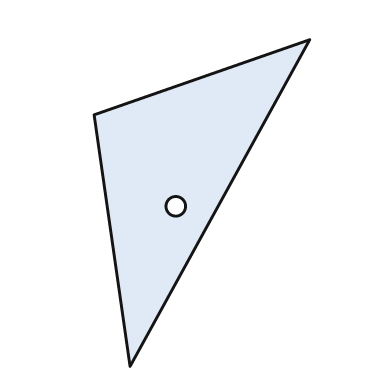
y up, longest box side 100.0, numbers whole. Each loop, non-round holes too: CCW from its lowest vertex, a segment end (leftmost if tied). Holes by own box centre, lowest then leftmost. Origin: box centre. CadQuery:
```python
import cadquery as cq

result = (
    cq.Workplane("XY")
    .moveTo(-22.0, -50.0)
    .lineTo(33.0, 50.0)
    .lineTo(-33.0, 27.0)
    .close()
    .moveTo(-8.0, -1.0)
    .circle(3.0)
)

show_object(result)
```